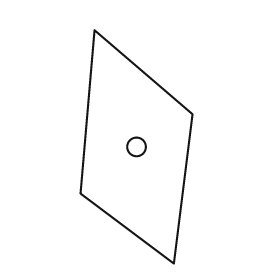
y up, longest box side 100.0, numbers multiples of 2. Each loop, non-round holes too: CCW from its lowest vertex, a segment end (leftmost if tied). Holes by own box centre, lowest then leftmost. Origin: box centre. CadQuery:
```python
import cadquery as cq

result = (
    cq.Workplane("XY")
    .moveTo(16.0, -50.0)
    .lineTo(24.0, 14.0)
    .lineTo(-18.0, 50.0)
    .lineTo(-24.0, -20.0)
    .close()
    .moveTo(0.0, 0.0)
    .circle(4.0)
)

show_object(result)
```